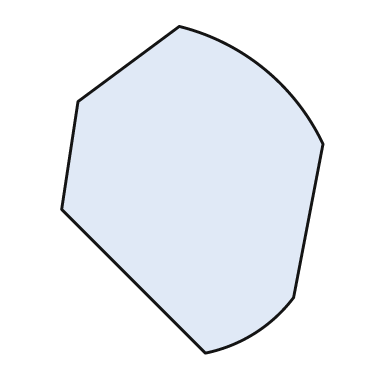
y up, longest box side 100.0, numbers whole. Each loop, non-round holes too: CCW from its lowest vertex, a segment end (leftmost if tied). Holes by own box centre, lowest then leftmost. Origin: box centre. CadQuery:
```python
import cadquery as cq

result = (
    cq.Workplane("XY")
    .moveTo(4.0, -50.0)
    .threePointArc((19.0, -44.0), (31.0, -33.0))
    .lineTo(40.0, 14.0)
    .threePointArc((22.0, 37.0), (-4.0, 50.0))
    .lineTo(-35.0, 27.0)
    .lineTo(-40.0, -6.0)
    .close()
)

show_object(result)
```